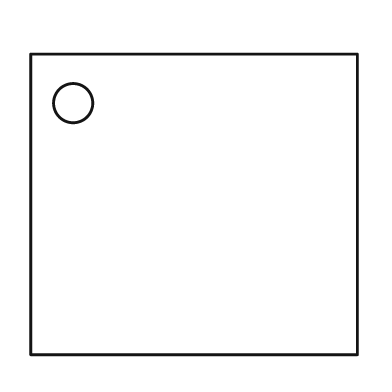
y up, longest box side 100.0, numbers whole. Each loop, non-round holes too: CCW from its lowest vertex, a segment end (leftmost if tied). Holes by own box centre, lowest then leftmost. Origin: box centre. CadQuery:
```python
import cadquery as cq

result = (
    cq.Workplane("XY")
    .moveTo(-50.0, -46.0)
    .lineTo(50.0, -46.0)
    .lineTo(50.0, 46.0)
    .lineTo(-50.0, 46.0)
    .close()
    .moveTo(-37.0, 31.0)
    .circle(6.0)
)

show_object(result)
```